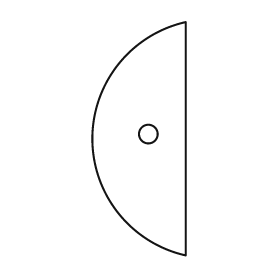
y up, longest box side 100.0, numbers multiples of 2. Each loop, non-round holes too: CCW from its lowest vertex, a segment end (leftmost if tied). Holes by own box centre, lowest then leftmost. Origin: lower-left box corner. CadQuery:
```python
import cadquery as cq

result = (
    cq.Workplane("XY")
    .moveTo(40.0, 0.0)
    .lineTo(40.0, 100.0)
    .threePointArc((0.0, 50.0), (40.0, 0.0))
    .close()
    .moveTo(24.0, 52.0)
    .circle(4.0)
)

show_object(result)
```